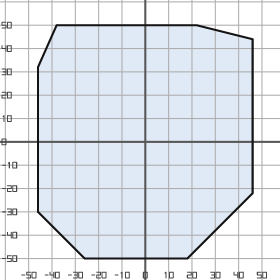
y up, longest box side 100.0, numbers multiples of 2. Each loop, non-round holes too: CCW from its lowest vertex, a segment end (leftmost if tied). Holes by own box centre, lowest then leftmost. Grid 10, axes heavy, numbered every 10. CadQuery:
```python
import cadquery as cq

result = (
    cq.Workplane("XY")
    .moveTo(-26.0, -50.0)
    .lineTo(18.0, -50.0)
    .lineTo(46.0, -22.0)
    .lineTo(46.0, 44.0)
    .lineTo(22.0, 50.0)
    .lineTo(-38.0, 50.0)
    .lineTo(-46.0, 32.0)
    .lineTo(-46.0, -30.0)
    .close()
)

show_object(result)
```